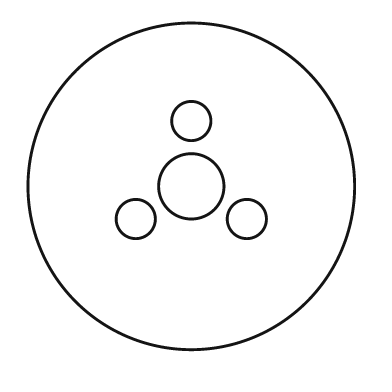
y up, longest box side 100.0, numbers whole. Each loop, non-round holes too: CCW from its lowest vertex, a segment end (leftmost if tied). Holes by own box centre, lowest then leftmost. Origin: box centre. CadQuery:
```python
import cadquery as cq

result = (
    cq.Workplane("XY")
    .moveTo(0.0, 0.0)
    .circle(50.0)
    .moveTo(-17.0, -10.0)
    .circle(6.0)
    .moveTo(17.0, -10.0)
    .circle(6.0)
    .moveTo(0.0, 0.0)
    .circle(10.0)
    .moveTo(0.0, 20.0)
    .circle(6.0)
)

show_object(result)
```